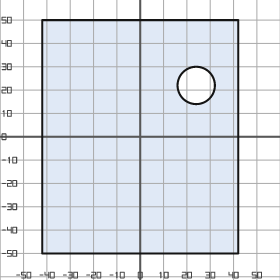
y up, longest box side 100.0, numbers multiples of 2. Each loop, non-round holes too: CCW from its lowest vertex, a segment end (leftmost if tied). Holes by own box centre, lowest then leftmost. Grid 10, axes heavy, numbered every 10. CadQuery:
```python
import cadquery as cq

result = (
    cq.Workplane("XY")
    .moveTo(-42.0, -50.0)
    .lineTo(42.0, -50.0)
    .lineTo(42.0, 50.0)
    .lineTo(-42.0, 50.0)
    .close()
    .moveTo(24.0, 22.0)
    .circle(8.0)
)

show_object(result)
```